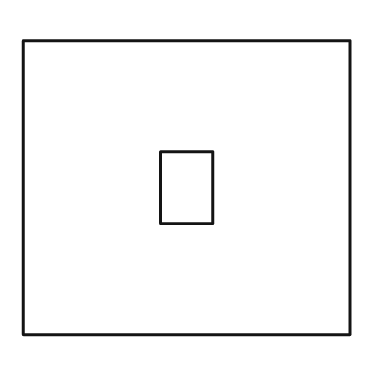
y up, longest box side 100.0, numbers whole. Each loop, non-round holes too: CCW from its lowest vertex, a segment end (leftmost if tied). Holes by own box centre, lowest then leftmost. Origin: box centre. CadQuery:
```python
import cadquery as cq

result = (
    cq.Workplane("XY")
    .moveTo(-50.0, -45.0)
    .lineTo(50.0, -45.0)
    .lineTo(50.0, 45.0)
    .lineTo(-50.0, 45.0)
    .close()
    .moveTo(-8.0, -11.0)
    .lineTo(8.0, -11.0)
    .lineTo(8.0, 11.0)
    .lineTo(-8.0, 11.0)
    .close()
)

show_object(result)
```